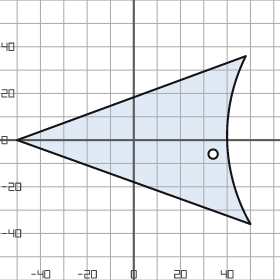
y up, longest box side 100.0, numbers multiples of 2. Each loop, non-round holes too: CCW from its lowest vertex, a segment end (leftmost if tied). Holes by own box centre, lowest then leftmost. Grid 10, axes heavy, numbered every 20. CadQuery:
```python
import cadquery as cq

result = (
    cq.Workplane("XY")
    .moveTo(50.0, -36.0)
    .threePointArc((40.0, 0.0), (48.0, 36.0))
    .lineTo(-50.0, 0.0)
    .close()
    .moveTo(34.0, -6.0)
    .circle(2.0)
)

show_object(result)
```